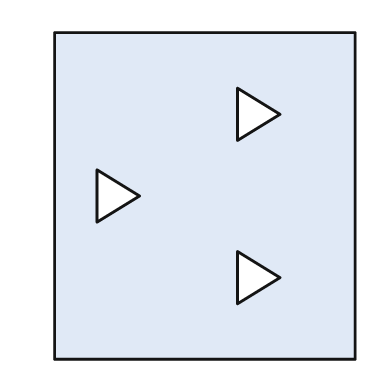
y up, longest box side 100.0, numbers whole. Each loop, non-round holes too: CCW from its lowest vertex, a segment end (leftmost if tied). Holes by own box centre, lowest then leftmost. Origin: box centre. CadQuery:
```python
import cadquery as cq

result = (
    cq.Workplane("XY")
    .moveTo(-46.0, -50.0)
    .lineTo(46.0, -50.0)
    .lineTo(46.0, 50.0)
    .lineTo(-46.0, 50.0)
    .close()
    .moveTo(10.0, -33.0)
    .lineTo(23.0, -25.0)
    .lineTo(10.0, -17.0)
    .close()
    .moveTo(-33.0, -8.0)
    .lineTo(-20.0, 0.0)
    .lineTo(-33.0, 8.0)
    .close()
    .moveTo(10.0, 17.0)
    .lineTo(23.0, 25.0)
    .lineTo(10.0, 33.0)
    .close()
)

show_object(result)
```